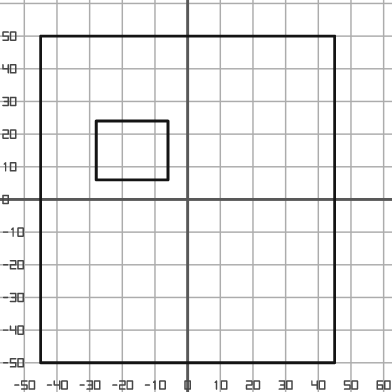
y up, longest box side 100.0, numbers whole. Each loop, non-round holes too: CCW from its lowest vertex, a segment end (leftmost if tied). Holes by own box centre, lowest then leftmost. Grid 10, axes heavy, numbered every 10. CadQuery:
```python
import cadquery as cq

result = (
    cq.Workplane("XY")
    .moveTo(-45.0, -50.0)
    .lineTo(45.0, -50.0)
    .lineTo(45.0, 50.0)
    .lineTo(-45.0, 50.0)
    .close()
    .moveTo(-28.0, 6.0)
    .lineTo(-6.0, 6.0)
    .lineTo(-6.0, 24.0)
    .lineTo(-28.0, 24.0)
    .close()
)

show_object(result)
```